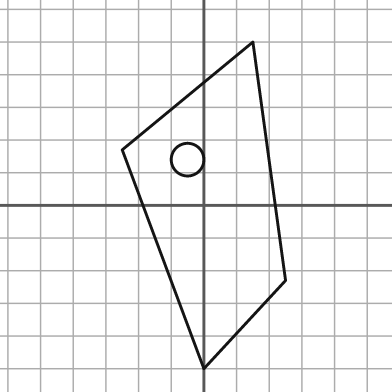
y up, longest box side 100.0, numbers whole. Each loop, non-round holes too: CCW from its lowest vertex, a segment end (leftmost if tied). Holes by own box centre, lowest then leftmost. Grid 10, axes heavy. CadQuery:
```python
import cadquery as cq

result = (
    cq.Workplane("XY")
    .moveTo(0.0, -50.0)
    .lineTo(25.0, -23.0)
    .lineTo(15.0, 50.0)
    .lineTo(-25.0, 17.0)
    .close()
    .moveTo(-5.0, 14.0)
    .circle(5.0)
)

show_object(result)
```